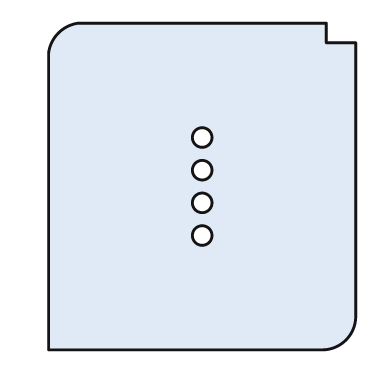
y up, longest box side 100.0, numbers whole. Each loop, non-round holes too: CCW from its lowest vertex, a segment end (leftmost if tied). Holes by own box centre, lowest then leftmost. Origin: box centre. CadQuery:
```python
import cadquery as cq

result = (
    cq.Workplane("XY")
    .moveTo(-47.0, -50.0)
    .lineTo(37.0, -50.0)
    .threePointArc((44.0, -47.0), (47.0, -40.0))
    .lineTo(47.0, 44.0)
    .lineTo(38.0, 44.0)
    .lineTo(38.0, 50.0)
    .lineTo(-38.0, 50.0)
    .threePointArc((-44.0, 47.0), (-47.0, 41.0))
    .close()
    .moveTo(0.0, -15.0)
    .circle(3.0)
    .moveTo(0.0, -5.0)
    .circle(3.0)
    .moveTo(0.0, 5.0)
    .circle(3.0)
    .moveTo(0.0, 15.0)
    .circle(3.0)
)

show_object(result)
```